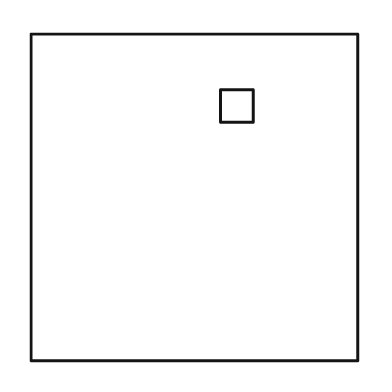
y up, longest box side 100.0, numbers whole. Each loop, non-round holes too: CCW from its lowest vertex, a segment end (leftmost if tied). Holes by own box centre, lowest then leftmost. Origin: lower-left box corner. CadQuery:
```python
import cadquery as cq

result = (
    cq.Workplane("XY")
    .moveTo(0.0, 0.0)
    .lineTo(100.0, 0.0)
    .lineTo(100.0, 100.0)
    .lineTo(0.0, 100.0)
    .close()
    .moveTo(58.0, 73.0)
    .lineTo(68.0, 73.0)
    .lineTo(68.0, 83.0)
    .lineTo(58.0, 83.0)
    .close()
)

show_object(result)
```